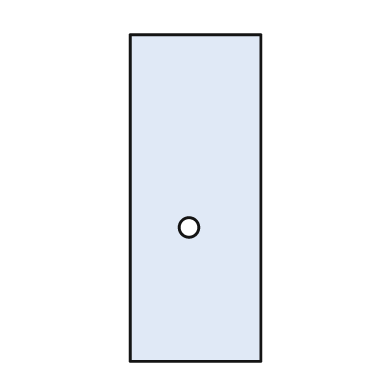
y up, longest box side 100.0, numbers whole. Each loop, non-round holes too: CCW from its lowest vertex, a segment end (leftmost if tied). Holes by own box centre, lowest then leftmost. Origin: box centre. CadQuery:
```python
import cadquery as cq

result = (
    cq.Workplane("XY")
    .moveTo(-20.0, -50.0)
    .lineTo(20.0, -50.0)
    .lineTo(20.0, 50.0)
    .lineTo(-20.0, 50.0)
    .close()
    .moveTo(-2.0, -9.0)
    .circle(3.0)
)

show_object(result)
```